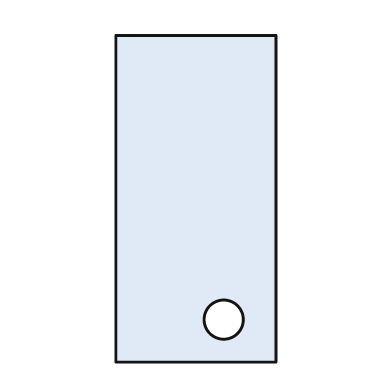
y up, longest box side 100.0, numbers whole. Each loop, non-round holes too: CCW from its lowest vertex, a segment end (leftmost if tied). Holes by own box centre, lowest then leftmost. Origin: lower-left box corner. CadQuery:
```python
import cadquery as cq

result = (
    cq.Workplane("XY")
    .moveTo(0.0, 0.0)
    .lineTo(49.0, 0.0)
    .lineTo(49.0, 100.0)
    .lineTo(0.0, 100.0)
    .close()
    .moveTo(33.0, 13.0)
    .circle(6.0)
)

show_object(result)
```